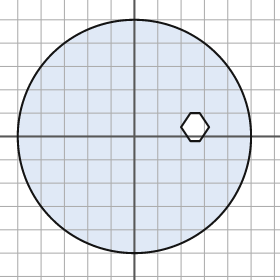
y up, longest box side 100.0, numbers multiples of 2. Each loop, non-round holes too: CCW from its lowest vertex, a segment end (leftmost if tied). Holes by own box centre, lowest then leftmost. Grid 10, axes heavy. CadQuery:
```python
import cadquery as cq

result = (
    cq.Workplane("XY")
    .moveTo(0.0, 0.0)
    .circle(50.0)
    .moveTo(24.0, -2.0)
    .lineTo(28.0, -2.0)
    .lineTo(32.0, 4.0)
    .lineTo(28.0, 10.0)
    .lineTo(24.0, 10.0)
    .lineTo(20.0, 4.0)
    .close()
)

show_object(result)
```